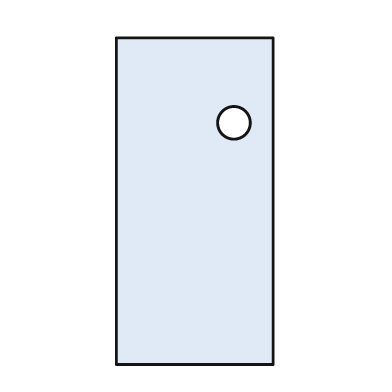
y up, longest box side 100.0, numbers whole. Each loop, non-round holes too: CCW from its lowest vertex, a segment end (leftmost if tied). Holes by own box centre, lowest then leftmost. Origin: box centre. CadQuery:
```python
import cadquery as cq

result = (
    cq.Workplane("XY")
    .moveTo(-24.0, -50.0)
    .lineTo(24.0, -50.0)
    .lineTo(24.0, 50.0)
    .lineTo(-24.0, 50.0)
    .close()
    .moveTo(12.0, 24.0)
    .circle(5.0)
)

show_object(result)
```